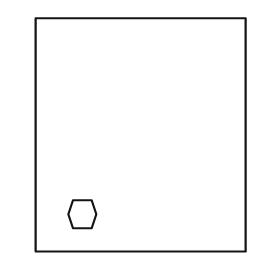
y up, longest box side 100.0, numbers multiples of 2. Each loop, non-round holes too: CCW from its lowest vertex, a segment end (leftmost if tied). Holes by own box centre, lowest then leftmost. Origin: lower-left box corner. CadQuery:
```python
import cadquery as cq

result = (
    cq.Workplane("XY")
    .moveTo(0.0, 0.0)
    .lineTo(90.0, 0.0)
    .lineTo(90.0, 100.0)
    .lineTo(0.0, 100.0)
    .close()
    .moveTo(16.0, 10.0)
    .lineTo(24.0, 10.0)
    .lineTo(26.0, 16.0)
    .lineTo(24.0, 22.0)
    .lineTo(16.0, 22.0)
    .lineTo(14.0, 16.0)
    .close()
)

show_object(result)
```